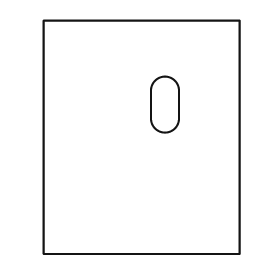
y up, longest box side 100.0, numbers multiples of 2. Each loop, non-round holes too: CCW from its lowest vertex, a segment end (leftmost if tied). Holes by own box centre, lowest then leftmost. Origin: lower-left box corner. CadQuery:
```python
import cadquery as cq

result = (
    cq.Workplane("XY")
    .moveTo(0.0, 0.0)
    .lineTo(84.0, 0.0)
    .lineTo(84.0, 100.0)
    .lineTo(0.0, 100.0)
    .close()
    .moveTo(46.0, 58.0)
    .threePointArc((52.0, 52.0), (58.0, 58.0))
    .lineTo(58.0, 70.0)
    .threePointArc((52.0, 76.0), (46.0, 70.0))
    .close()
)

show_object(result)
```